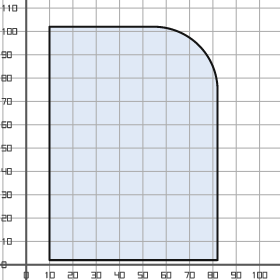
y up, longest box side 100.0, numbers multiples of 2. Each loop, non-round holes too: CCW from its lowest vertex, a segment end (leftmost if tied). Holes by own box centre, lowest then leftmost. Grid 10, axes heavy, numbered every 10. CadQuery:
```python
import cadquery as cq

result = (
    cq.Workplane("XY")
    .moveTo(10.0, 2.0)
    .lineTo(82.0, 2.0)
    .lineTo(82.0, 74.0)
    .threePointArc((74.0, 94.0), (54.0, 102.0))
    .lineTo(10.0, 102.0)
    .close()
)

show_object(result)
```